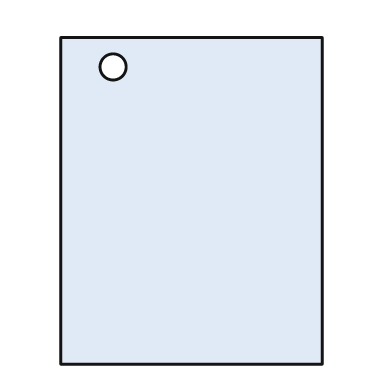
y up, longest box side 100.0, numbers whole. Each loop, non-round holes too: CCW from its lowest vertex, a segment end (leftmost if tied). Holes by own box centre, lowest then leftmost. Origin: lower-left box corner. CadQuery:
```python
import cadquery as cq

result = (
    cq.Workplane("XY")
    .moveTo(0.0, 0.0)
    .lineTo(80.0, 0.0)
    .lineTo(80.0, 100.0)
    .lineTo(0.0, 100.0)
    .close()
    .moveTo(16.0, 91.0)
    .circle(4.0)
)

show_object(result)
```